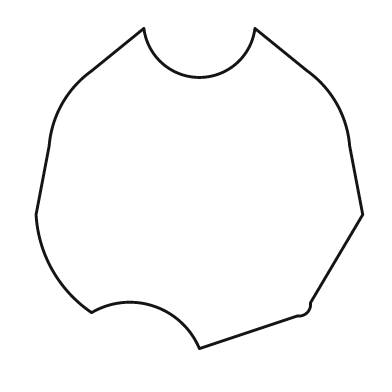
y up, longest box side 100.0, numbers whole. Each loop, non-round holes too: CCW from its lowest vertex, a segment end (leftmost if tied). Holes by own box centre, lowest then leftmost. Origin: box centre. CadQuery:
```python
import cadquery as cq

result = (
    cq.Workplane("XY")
    .moveTo(0.0, -49.0)
    .lineTo(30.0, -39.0)
    .threePointArc((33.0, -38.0), (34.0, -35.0))
    .lineTo(50.0, -8.0)
    .lineTo(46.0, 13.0)
    .threePointArc((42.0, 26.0), (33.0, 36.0))
    .lineTo(17.0, 49.0)
    .threePointArc((0.0, 34.0), (-17.0, 49.0))
    .lineTo(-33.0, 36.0)
    .threePointArc((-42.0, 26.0), (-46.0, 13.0))
    .lineTo(-50.0, -8.0)
    .threePointArc((-45.0, -25.0), (-33.0, -38.0))
    .threePointArc((-14.0, -36.0), (0.0, -49.0))
    .close()
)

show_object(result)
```